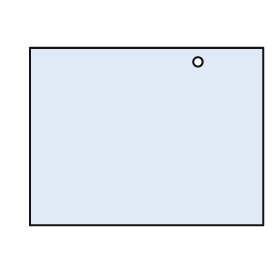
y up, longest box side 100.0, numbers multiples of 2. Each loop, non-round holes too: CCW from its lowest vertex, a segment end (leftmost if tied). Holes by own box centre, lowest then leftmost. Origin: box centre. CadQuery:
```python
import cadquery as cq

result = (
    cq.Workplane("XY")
    .moveTo(-50.0, -38.0)
    .lineTo(50.0, -38.0)
    .lineTo(50.0, 38.0)
    .lineTo(-50.0, 38.0)
    .close()
    .moveTo(22.0, 32.0)
    .circle(2.0)
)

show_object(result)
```